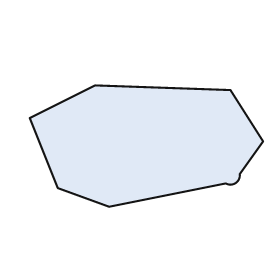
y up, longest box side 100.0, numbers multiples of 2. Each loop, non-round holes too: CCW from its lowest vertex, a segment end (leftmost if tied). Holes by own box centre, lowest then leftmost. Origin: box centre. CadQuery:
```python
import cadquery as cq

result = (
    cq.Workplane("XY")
    .moveTo(-16.0, -26.0)
    .lineTo(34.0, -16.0)
    .threePointArc((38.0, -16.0), (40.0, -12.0))
    .lineTo(50.0, 2.0)
    .lineTo(36.0, 24.0)
    .lineTo(-22.0, 26.0)
    .lineTo(-50.0, 12.0)
    .lineTo(-38.0, -18.0)
    .close()
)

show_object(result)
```